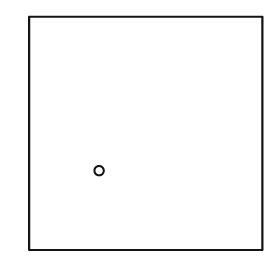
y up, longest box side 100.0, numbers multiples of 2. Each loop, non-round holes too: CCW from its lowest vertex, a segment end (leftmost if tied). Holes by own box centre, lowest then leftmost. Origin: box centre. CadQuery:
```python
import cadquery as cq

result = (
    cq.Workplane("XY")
    .moveTo(-50.0, -50.0)
    .lineTo(50.0, -50.0)
    .lineTo(50.0, 50.0)
    .lineTo(-50.0, 50.0)
    .close()
    .moveTo(-20.0, -16.0)
    .circle(2.0)
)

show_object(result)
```